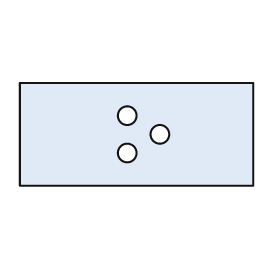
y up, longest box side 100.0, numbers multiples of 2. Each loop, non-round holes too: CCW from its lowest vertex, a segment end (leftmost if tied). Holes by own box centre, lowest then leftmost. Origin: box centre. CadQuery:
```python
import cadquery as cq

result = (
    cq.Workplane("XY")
    .moveTo(-50.0, -22.0)
    .lineTo(50.0, -22.0)
    .lineTo(50.0, 22.0)
    .lineTo(-50.0, 22.0)
    .close()
    .moveTo(-4.0, -8.0)
    .circle(4.0)
    .moveTo(10.0, 0.0)
    .circle(4.0)
    .moveTo(-4.0, 8.0)
    .circle(4.0)
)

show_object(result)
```